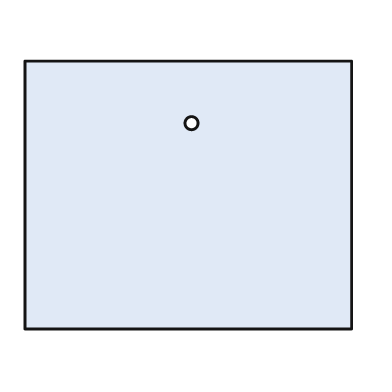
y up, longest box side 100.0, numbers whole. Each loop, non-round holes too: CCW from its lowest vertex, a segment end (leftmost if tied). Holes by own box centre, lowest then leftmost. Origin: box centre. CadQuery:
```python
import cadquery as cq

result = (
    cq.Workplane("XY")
    .moveTo(-50.0, -41.0)
    .lineTo(50.0, -41.0)
    .lineTo(50.0, 41.0)
    .lineTo(-50.0, 41.0)
    .close()
    .moveTo(1.0, 22.0)
    .circle(2.0)
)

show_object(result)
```